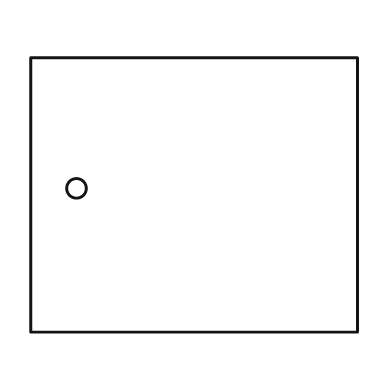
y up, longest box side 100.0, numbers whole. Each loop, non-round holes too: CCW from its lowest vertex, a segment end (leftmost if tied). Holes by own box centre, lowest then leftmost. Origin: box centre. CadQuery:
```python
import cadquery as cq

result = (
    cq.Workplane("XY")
    .moveTo(-50.0, -42.0)
    .lineTo(50.0, -42.0)
    .lineTo(50.0, 42.0)
    .lineTo(-50.0, 42.0)
    .close()
    .moveTo(-36.0, 2.0)
    .circle(3.0)
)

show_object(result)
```